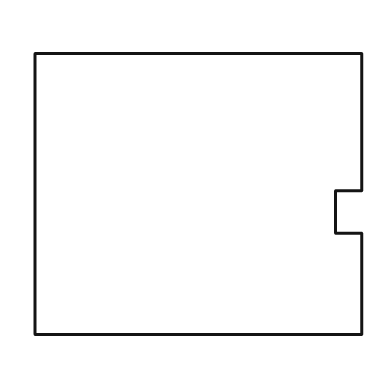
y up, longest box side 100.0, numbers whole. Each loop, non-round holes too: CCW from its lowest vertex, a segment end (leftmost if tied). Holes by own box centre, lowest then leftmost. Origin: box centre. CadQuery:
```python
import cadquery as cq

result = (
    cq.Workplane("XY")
    .moveTo(-50.0, -43.0)
    .lineTo(50.0, -43.0)
    .lineTo(50.0, -12.0)
    .lineTo(42.0, -12.0)
    .lineTo(42.0, 1.0)
    .lineTo(50.0, 1.0)
    .lineTo(50.0, 43.0)
    .lineTo(-50.0, 43.0)
    .close()
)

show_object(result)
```